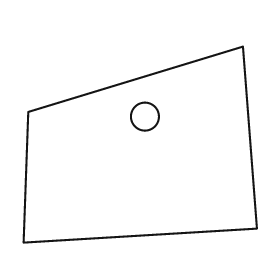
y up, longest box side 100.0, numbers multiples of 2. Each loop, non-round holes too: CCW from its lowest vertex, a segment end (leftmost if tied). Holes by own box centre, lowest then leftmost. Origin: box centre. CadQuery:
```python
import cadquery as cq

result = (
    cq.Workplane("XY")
    .moveTo(-50.0, -42.0)
    .lineTo(50.0, -36.0)
    .lineTo(44.0, 42.0)
    .lineTo(-48.0, 14.0)
    .close()
    .moveTo(2.0, 12.0)
    .circle(6.0)
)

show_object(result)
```